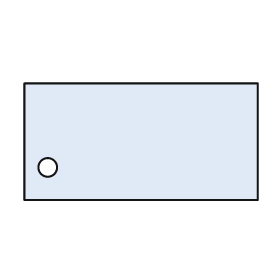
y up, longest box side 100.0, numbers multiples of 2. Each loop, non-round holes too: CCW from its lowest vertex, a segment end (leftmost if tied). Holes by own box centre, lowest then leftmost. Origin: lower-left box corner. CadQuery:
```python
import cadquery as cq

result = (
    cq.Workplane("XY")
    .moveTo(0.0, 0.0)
    .lineTo(100.0, 0.0)
    .lineTo(100.0, 50.0)
    .lineTo(0.0, 50.0)
    .close()
    .moveTo(10.0, 14.0)
    .circle(4.0)
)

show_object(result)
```